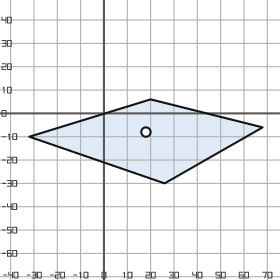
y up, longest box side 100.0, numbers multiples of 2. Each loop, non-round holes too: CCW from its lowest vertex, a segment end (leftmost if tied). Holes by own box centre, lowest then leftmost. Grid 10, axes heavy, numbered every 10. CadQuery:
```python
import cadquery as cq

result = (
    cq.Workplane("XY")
    .moveTo(26.0, -30.0)
    .lineTo(68.0, -6.0)
    .lineTo(20.0, 6.0)
    .lineTo(-32.0, -10.0)
    .close()
    .moveTo(18.0, -8.0)
    .circle(2.0)
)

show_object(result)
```